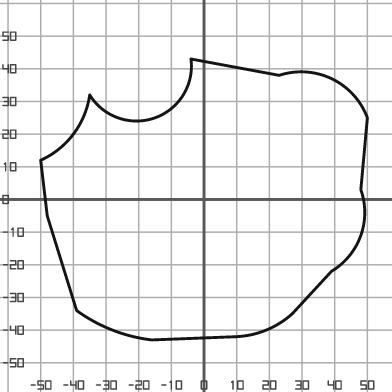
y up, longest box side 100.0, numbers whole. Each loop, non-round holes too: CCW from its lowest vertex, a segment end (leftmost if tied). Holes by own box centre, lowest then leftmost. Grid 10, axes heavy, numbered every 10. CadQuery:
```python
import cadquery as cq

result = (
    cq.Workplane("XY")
    .moveTo(-16.0, -43.0)
    .lineTo(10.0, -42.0)
    .threePointArc((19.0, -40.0), (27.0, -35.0))
    .lineTo(39.0, -22.0)
    .threePointArc((48.0, -11.0), (48.0, 3.0))
    .lineTo(50.0, 25.0)
    .threePointArc((39.0, 37.0), (23.0, 38.0))
    .lineTo(-4.0, 43.0)
    .threePointArc((-15.0, 25.0), (-35.0, 32.0))
    .threePointArc((-40.0, 20.0), (-50.0, 12.0))
    .lineTo(-48.0, -5.0)
    .lineTo(-39.0, -34.0)
    .threePointArc((-28.0, -40.0), (-16.0, -43.0))
    .close()
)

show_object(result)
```